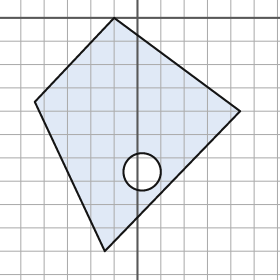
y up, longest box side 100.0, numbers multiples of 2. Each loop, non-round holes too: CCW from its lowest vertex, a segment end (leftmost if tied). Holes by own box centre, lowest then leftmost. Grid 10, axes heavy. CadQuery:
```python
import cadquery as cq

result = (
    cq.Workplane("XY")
    .moveTo(-14.0, -100.0)
    .lineTo(44.0, -40.0)
    .lineTo(-10.0, 0.0)
    .lineTo(-44.0, -36.0)
    .close()
    .moveTo(2.0, -66.0)
    .circle(8.0)
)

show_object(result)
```